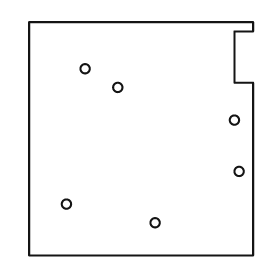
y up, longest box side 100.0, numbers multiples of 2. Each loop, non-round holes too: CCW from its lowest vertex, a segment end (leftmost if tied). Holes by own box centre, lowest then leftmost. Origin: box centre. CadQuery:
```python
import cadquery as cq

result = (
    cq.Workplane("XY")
    .moveTo(-48.0, -50.0)
    .lineTo(48.0, -50.0)
    .lineTo(48.0, 24.0)
    .lineTo(40.0, 24.0)
    .lineTo(40.0, 46.0)
    .lineTo(48.0, 46.0)
    .lineTo(48.0, 50.0)
    .lineTo(-48.0, 50.0)
    .close()
    .moveTo(6.0, -36.0)
    .circle(2.0)
    .moveTo(-32.0, -28.0)
    .circle(2.0)
    .moveTo(42.0, -14.0)
    .circle(2.0)
    .moveTo(40.0, 8.0)
    .circle(2.0)
    .moveTo(-10.0, 22.0)
    .circle(2.0)
    .moveTo(-24.0, 30.0)
    .circle(2.0)
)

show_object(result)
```